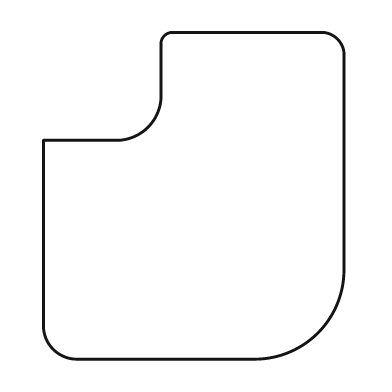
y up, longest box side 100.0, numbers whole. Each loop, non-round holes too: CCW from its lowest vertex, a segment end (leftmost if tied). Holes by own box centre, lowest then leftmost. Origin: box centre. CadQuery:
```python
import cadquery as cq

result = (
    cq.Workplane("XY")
    .moveTo(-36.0, -50.0)
    .lineTo(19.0, -50.0)
    .threePointArc((38.0, -42.0), (46.0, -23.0))
    .lineTo(46.0, 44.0)
    .threePointArc((44.0, 48.0), (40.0, 50.0))
    .lineTo(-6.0, 50.0)
    .threePointArc((-9.0, 49.0), (-10.0, 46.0))
    .lineTo(-10.0, 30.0)
    .threePointArc((-14.0, 21.0), (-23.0, 17.0))
    .lineTo(-46.0, 17.0)
    .lineTo(-46.0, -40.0)
    .threePointArc((-43.0, -47.0), (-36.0, -50.0))
    .close()
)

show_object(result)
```